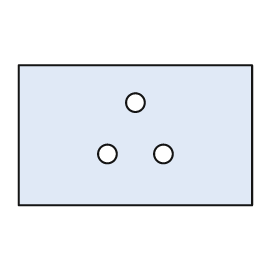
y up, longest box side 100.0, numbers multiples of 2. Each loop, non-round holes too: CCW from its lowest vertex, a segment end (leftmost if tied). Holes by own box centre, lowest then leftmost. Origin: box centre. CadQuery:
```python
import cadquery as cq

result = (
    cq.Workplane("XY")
    .moveTo(-50.0, -30.0)
    .lineTo(50.0, -30.0)
    .lineTo(50.0, 30.0)
    .lineTo(-50.0, 30.0)
    .close()
    .moveTo(-12.0, -8.0)
    .circle(4.0)
    .moveTo(12.0, -8.0)
    .circle(4.0)
    .moveTo(0.0, 14.0)
    .circle(4.0)
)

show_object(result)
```